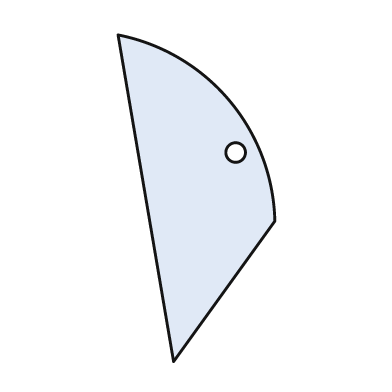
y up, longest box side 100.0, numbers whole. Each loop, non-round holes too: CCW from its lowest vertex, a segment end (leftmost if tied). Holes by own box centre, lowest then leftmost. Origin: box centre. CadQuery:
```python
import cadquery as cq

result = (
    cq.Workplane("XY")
    .moveTo(-7.0, -50.0)
    .lineTo(24.0, -7.0)
    .threePointArc((10.0, 30.0), (-24.0, 50.0))
    .close()
    .moveTo(12.0, 14.0)
    .circle(3.0)
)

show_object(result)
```